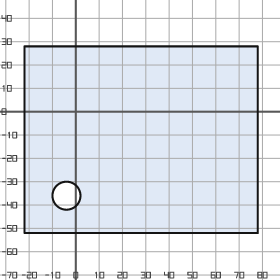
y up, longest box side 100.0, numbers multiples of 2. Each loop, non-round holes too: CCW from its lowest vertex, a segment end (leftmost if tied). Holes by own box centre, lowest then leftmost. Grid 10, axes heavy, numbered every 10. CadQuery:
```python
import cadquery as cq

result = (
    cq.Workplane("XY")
    .moveTo(-22.0, -52.0)
    .lineTo(78.0, -52.0)
    .lineTo(78.0, 28.0)
    .lineTo(-22.0, 28.0)
    .close()
    .moveTo(-4.0, -36.0)
    .circle(6.0)
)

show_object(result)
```